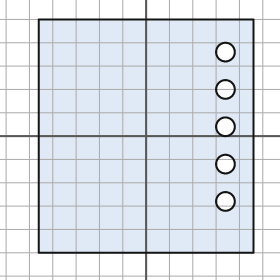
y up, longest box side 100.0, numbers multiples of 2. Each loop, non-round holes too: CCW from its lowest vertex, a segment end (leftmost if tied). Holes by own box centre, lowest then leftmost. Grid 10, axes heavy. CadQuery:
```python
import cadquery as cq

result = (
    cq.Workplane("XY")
    .moveTo(-46.0, -50.0)
    .lineTo(46.0, -50.0)
    .lineTo(46.0, 50.0)
    .lineTo(-46.0, 50.0)
    .close()
    .moveTo(34.0, -28.0)
    .circle(4.0)
    .moveTo(34.0, -12.0)
    .circle(4.0)
    .moveTo(34.0, 4.0)
    .circle(4.0)
    .moveTo(34.0, 20.0)
    .circle(4.0)
    .moveTo(34.0, 36.0)
    .circle(4.0)
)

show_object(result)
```